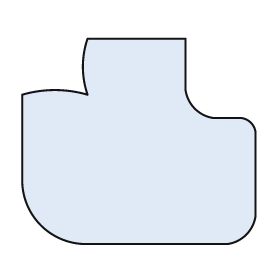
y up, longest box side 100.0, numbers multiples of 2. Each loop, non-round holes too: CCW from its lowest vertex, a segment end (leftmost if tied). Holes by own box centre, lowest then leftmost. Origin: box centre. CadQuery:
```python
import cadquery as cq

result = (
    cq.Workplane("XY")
    .moveTo(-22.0, -44.0)
    .lineTo(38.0, -44.0)
    .threePointArc((46.0, -40.0), (50.0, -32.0))
    .lineTo(50.0, 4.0)
    .threePointArc((48.0, 8.0), (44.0, 10.0))
    .lineTo(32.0, 10.0)
    .threePointArc((24.0, 14.0), (20.0, 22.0))
    .lineTo(20.0, 44.0)
    .lineTo(-22.0, 44.0)
    .threePointArc((-24.0, 32.0), (-22.0, 20.0))
    .threePointArc((-36.0, 22.0), (-50.0, 20.0))
    .lineTo(-50.0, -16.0)
    .threePointArc((-42.0, -36.0), (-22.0, -44.0))
    .close()
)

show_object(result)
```